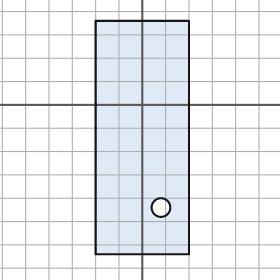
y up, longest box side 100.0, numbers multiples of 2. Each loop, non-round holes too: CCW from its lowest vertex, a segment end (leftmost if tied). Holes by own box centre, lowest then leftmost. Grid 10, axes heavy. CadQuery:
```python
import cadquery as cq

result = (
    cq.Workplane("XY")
    .moveTo(-20.0, -64.0)
    .lineTo(20.0, -64.0)
    .lineTo(20.0, 36.0)
    .lineTo(-20.0, 36.0)
    .close()
    .moveTo(8.0, -44.0)
    .circle(4.0)
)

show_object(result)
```